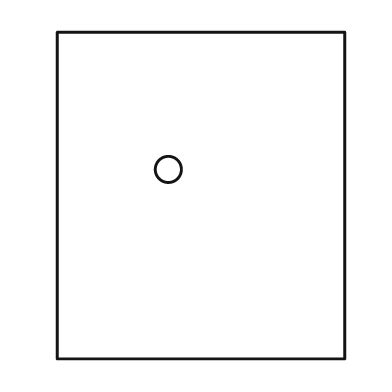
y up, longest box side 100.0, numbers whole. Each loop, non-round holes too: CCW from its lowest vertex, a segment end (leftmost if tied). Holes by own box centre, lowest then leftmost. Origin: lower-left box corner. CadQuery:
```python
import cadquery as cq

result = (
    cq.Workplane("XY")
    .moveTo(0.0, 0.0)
    .lineTo(88.0, 0.0)
    .lineTo(88.0, 100.0)
    .lineTo(0.0, 100.0)
    .close()
    .moveTo(34.0, 58.0)
    .circle(4.0)
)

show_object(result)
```